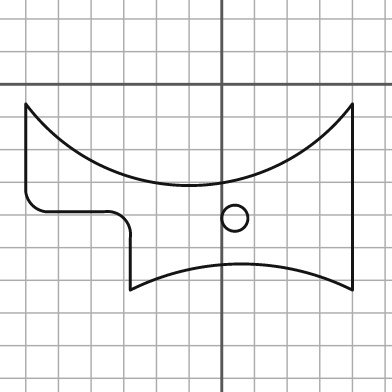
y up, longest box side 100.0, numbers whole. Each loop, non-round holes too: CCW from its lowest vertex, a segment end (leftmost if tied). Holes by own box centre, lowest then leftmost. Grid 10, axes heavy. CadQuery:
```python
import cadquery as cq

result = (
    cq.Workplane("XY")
    .moveTo(-28.0, -63.0)
    .threePointArc((6.0, -55.0), (40.0, -63.0))
    .lineTo(40.0, -6.0)
    .threePointArc((-10.0, -31.0), (-60.0, -6.0))
    .lineTo(-60.0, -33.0)
    .threePointArc((-58.0, -37.0), (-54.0, -39.0))
    .lineTo(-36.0, -39.0)
    .threePointArc((-30.0, -41.0), (-28.0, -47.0))
    .close()
    .moveTo(4.0, -41.0)
    .circle(4.0)
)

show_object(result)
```